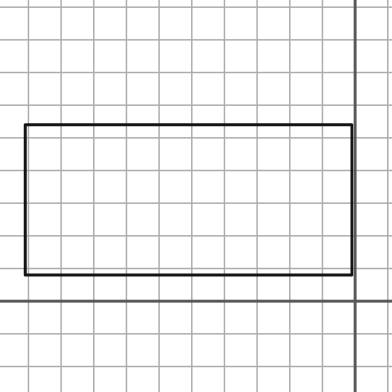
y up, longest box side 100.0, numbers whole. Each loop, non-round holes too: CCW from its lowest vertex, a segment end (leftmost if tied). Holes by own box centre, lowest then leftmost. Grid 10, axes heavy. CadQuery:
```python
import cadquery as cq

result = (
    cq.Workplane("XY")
    .moveTo(-101.0, 8.0)
    .lineTo(-1.0, 8.0)
    .lineTo(-1.0, 54.0)
    .lineTo(-101.0, 54.0)
    .close()
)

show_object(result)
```